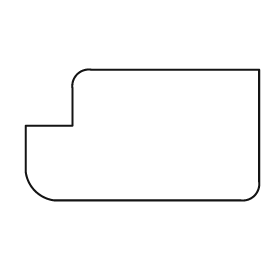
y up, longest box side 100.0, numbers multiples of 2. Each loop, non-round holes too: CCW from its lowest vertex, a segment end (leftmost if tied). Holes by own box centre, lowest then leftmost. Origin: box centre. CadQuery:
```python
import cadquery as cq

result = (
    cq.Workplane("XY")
    .moveTo(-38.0, -28.0)
    .lineTo(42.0, -28.0)
    .threePointArc((48.0, -26.0), (50.0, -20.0))
    .lineTo(50.0, 28.0)
    .lineTo(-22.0, 28.0)
    .threePointArc((-28.0, 26.0), (-30.0, 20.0))
    .lineTo(-30.0, 4.0)
    .lineTo(-50.0, 4.0)
    .lineTo(-50.0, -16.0)
    .threePointArc((-46.0, -24.0), (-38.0, -28.0))
    .close()
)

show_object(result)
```